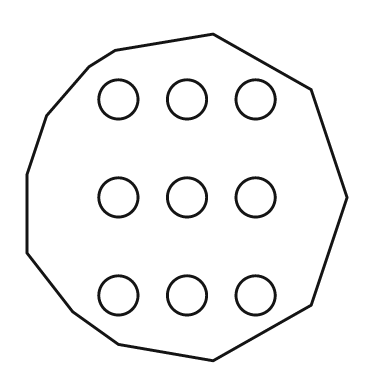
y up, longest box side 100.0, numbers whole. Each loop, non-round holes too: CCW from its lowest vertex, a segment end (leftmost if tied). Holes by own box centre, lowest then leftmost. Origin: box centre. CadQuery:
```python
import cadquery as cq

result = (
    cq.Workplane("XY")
    .moveTo(8.0, -50.0)
    .lineTo(38.0, -33.0)
    .lineTo(49.0, 0.0)
    .lineTo(38.0, 33.0)
    .lineTo(8.0, 50.0)
    .lineTo(-22.0, 45.0)
    .lineTo(-30.0, 40.0)
    .lineTo(-43.0, 25.0)
    .lineTo(-49.0, 7.0)
    .lineTo(-49.0, -17.0)
    .lineTo(-35.0, -35.0)
    .lineTo(-21.0, -45.0)
    .close()
    .moveTo(-21.0, -30.0)
    .circle(6.0)
    .moveTo(0.0, -30.0)
    .circle(6.0)
    .moveTo(21.0, -30.0)
    .circle(6.0)
    .moveTo(-21.0, 0.0)
    .circle(6.0)
    .moveTo(0.0, 0.0)
    .circle(6.0)
    .moveTo(21.0, 0.0)
    .circle(6.0)
    .moveTo(-21.0, 30.0)
    .circle(6.0)
    .moveTo(0.0, 30.0)
    .circle(6.0)
    .moveTo(21.0, 30.0)
    .circle(6.0)
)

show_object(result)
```